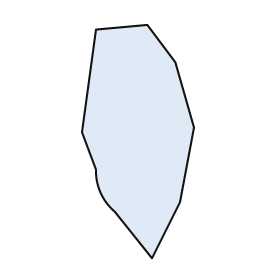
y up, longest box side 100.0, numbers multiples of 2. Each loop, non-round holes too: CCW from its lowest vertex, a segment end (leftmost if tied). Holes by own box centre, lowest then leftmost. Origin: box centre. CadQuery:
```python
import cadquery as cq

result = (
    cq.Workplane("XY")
    .moveTo(6.0, -50.0)
    .lineTo(18.0, -26.0)
    .lineTo(24.0, 6.0)
    .lineTo(16.0, 34.0)
    .lineTo(4.0, 50.0)
    .lineTo(-18.0, 48.0)
    .lineTo(-24.0, 4.0)
    .lineTo(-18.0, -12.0)
    .threePointArc((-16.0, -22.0), (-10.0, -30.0))
    .close()
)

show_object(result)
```